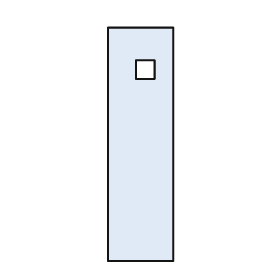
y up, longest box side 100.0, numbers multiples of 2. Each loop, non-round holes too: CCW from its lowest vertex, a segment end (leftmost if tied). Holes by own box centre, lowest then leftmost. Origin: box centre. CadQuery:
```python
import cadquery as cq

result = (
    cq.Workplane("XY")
    .moveTo(-14.0, -50.0)
    .lineTo(14.0, -50.0)
    .lineTo(14.0, 50.0)
    .lineTo(-14.0, 50.0)
    .close()
    .moveTo(-2.0, 28.0)
    .lineTo(6.0, 28.0)
    .lineTo(6.0, 36.0)
    .lineTo(-2.0, 36.0)
    .close()
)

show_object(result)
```